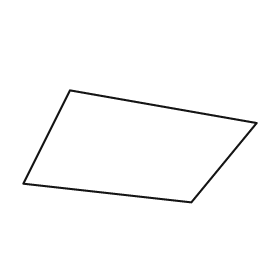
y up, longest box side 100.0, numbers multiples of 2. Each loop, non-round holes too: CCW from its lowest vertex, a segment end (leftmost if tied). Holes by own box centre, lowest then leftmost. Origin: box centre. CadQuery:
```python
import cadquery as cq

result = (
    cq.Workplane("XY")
    .moveTo(22.0, -24.0)
    .lineTo(50.0, 10.0)
    .lineTo(-30.0, 24.0)
    .lineTo(-50.0, -16.0)
    .close()
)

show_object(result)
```